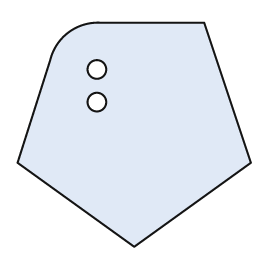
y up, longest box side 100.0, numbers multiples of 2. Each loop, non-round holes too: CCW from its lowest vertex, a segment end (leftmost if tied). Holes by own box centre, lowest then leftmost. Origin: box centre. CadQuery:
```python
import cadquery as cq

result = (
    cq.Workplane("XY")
    .moveTo(0.0, -48.0)
    .lineTo(50.0, -12.0)
    .lineTo(30.0, 48.0)
    .lineTo(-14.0, 48.0)
    .threePointArc((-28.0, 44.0), (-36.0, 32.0))
    .lineTo(-50.0, -12.0)
    .close()
    .moveTo(-16.0, 14.0)
    .circle(4.0)
    .moveTo(-16.0, 28.0)
    .circle(4.0)
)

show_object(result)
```